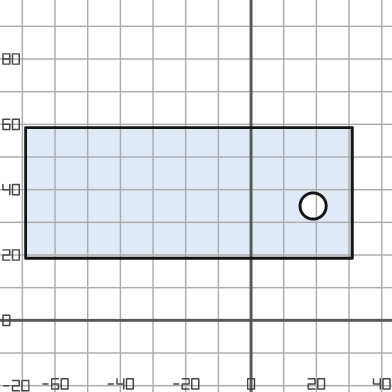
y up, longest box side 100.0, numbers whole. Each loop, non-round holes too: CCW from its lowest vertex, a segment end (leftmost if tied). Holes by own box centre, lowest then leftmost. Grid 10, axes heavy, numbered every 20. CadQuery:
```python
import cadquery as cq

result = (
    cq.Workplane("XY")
    .moveTo(-69.0, 19.0)
    .lineTo(31.0, 19.0)
    .lineTo(31.0, 59.0)
    .lineTo(-69.0, 59.0)
    .close()
    .moveTo(19.0, 35.0)
    .circle(4.0)
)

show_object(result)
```